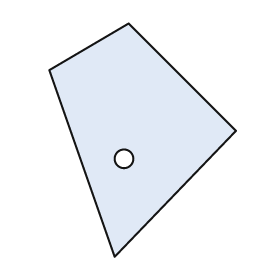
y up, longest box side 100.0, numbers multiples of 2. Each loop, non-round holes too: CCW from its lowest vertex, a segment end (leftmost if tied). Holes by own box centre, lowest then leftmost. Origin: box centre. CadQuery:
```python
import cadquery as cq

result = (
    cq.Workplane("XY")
    .moveTo(-12.0, -50.0)
    .lineTo(40.0, 4.0)
    .lineTo(-6.0, 50.0)
    .lineTo(-40.0, 30.0)
    .close()
    .moveTo(-8.0, -8.0)
    .circle(4.0)
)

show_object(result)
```